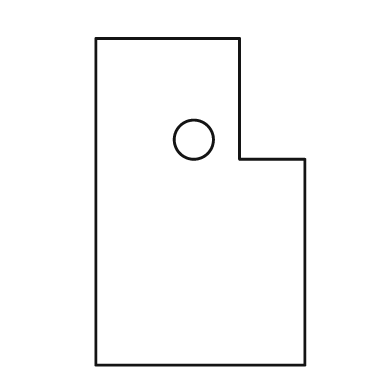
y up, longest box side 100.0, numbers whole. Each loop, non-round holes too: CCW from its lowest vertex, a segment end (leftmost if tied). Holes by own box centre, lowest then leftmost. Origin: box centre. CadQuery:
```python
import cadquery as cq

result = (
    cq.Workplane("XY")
    .moveTo(-32.0, -50.0)
    .lineTo(32.0, -50.0)
    .lineTo(32.0, 13.0)
    .lineTo(12.0, 13.0)
    .lineTo(12.0, 50.0)
    .lineTo(-32.0, 50.0)
    .close()
    .moveTo(-2.0, 19.0)
    .circle(6.0)
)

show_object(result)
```